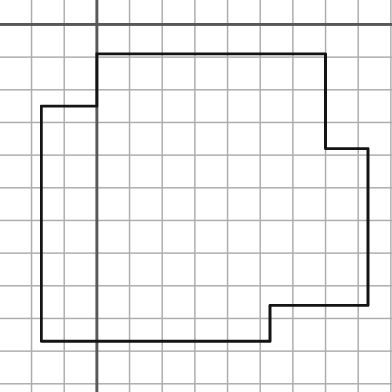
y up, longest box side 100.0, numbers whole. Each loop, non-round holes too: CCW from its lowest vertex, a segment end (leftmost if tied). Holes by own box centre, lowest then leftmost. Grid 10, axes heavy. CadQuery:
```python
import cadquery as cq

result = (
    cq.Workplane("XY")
    .moveTo(-17.0, -97.0)
    .lineTo(53.0, -97.0)
    .lineTo(53.0, -86.0)
    .lineTo(83.0, -86.0)
    .lineTo(83.0, -38.0)
    .lineTo(70.0, -38.0)
    .lineTo(70.0, -9.0)
    .lineTo(0.0, -9.0)
    .lineTo(0.0, -25.0)
    .lineTo(-17.0, -25.0)
    .close()
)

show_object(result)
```